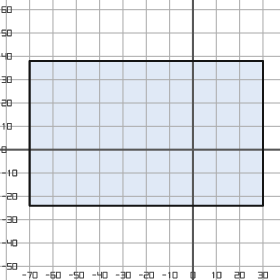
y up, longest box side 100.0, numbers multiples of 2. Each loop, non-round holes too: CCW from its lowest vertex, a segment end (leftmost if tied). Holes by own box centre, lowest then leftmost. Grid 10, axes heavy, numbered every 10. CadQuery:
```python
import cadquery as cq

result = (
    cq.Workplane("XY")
    .moveTo(-70.0, -24.0)
    .lineTo(30.0, -24.0)
    .lineTo(30.0, 38.0)
    .lineTo(-70.0, 38.0)
    .close()
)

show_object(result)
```